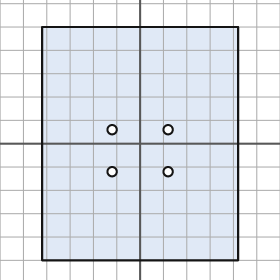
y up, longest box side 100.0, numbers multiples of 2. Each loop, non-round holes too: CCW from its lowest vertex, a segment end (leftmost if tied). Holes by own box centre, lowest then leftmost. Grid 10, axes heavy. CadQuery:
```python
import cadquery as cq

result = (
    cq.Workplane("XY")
    .moveTo(-42.0, -50.0)
    .lineTo(42.0, -50.0)
    .lineTo(42.0, 50.0)
    .lineTo(-42.0, 50.0)
    .close()
    .moveTo(-12.0, -12.0)
    .circle(2.0)
    .moveTo(12.0, -12.0)
    .circle(2.0)
    .moveTo(-12.0, 6.0)
    .circle(2.0)
    .moveTo(12.0, 6.0)
    .circle(2.0)
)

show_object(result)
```